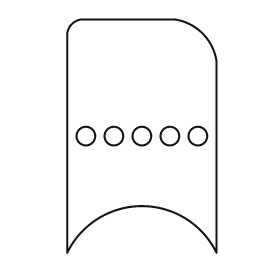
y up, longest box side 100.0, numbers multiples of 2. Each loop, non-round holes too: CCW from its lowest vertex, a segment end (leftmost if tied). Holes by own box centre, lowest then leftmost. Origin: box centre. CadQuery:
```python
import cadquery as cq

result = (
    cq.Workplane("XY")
    .moveTo(-32.0, -50.0)
    .threePointArc((0.0, -30.0), (32.0, -50.0))
    .lineTo(32.0, 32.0)
    .threePointArc((26.0, 44.0), (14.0, 50.0))
    .lineTo(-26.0, 50.0)
    .threePointArc((-30.0, 48.0), (-32.0, 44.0))
    .close()
    .moveTo(-24.0, 0.0)
    .circle(4.0)
    .moveTo(-12.0, 0.0)
    .circle(4.0)
    .moveTo(0.0, 0.0)
    .circle(4.0)
    .moveTo(12.0, 0.0)
    .circle(4.0)
    .moveTo(24.0, 0.0)
    .circle(4.0)
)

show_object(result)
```